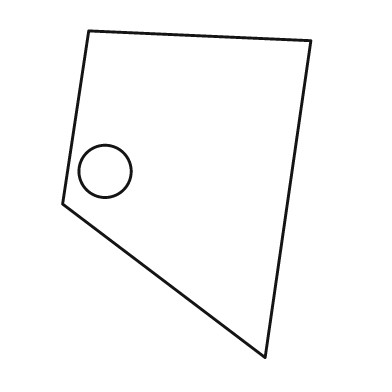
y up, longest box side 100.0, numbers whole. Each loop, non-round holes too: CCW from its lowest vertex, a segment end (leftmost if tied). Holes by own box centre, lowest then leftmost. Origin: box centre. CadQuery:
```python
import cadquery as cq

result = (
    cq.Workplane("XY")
    .moveTo(24.0, -50.0)
    .lineTo(38.0, 47.0)
    .lineTo(-30.0, 50.0)
    .lineTo(-38.0, -3.0)
    .close()
    .moveTo(-25.0, 7.0)
    .circle(8.0)
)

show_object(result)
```